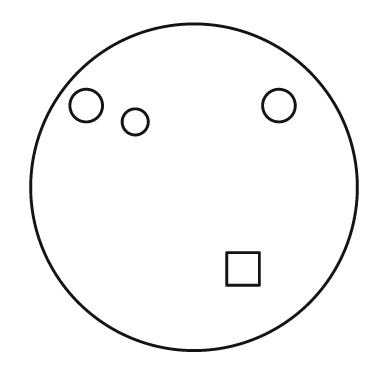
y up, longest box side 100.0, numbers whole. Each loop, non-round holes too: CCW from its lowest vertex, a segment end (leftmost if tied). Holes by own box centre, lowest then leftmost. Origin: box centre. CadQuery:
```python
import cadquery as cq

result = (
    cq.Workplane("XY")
    .moveTo(0.0, 0.0)
    .circle(50.0)
    .moveTo(10.0, -30.0)
    .lineTo(20.0, -30.0)
    .lineTo(20.0, -20.0)
    .lineTo(10.0, -20.0)
    .close()
    .moveTo(-18.0, 20.0)
    .circle(4.0)
    .moveTo(-33.0, 25.0)
    .circle(5.0)
    .moveTo(26.0, 25.0)
    .circle(5.0)
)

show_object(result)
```